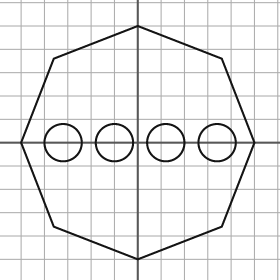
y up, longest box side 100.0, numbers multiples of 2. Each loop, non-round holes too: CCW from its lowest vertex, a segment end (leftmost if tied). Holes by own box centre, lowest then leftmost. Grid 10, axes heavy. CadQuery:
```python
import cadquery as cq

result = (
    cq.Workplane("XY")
    .moveTo(0.0, -50.0)
    .lineTo(36.0, -36.0)
    .lineTo(50.0, 0.0)
    .lineTo(36.0, 36.0)
    .lineTo(0.0, 50.0)
    .lineTo(-36.0, 36.0)
    .lineTo(-50.0, 0.0)
    .lineTo(-36.0, -36.0)
    .close()
    .moveTo(-32.0, 0.0)
    .circle(8.0)
    .moveTo(-10.0, 0.0)
    .circle(8.0)
    .moveTo(12.0, 0.0)
    .circle(8.0)
    .moveTo(34.0, 0.0)
    .circle(8.0)
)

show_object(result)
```